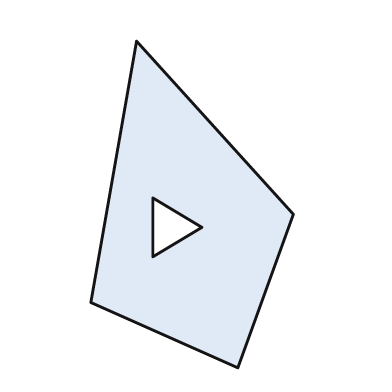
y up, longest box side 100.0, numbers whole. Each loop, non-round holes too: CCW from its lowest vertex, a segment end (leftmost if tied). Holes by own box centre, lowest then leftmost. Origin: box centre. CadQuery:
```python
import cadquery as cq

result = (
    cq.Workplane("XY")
    .moveTo(14.0, -50.0)
    .lineTo(31.0, -3.0)
    .lineTo(-17.0, 50.0)
    .lineTo(-31.0, -30.0)
    .close()
    .moveTo(-12.0, -16.0)
    .lineTo(3.0, -7.0)
    .lineTo(-12.0, 2.0)
    .close()
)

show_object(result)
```